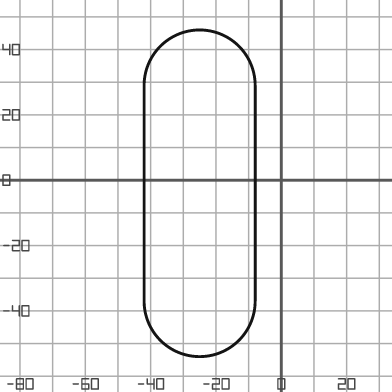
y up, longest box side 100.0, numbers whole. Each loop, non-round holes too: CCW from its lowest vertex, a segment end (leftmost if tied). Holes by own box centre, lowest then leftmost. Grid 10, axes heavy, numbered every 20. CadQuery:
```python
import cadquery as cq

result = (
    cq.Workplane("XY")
    .moveTo(-42.0, -37.0)
    .threePointArc((-25.0, -54.0), (-8.0, -37.0))
    .lineTo(-8.0, 29.0)
    .threePointArc((-25.0, 46.0), (-42.0, 29.0))
    .close()
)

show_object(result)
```